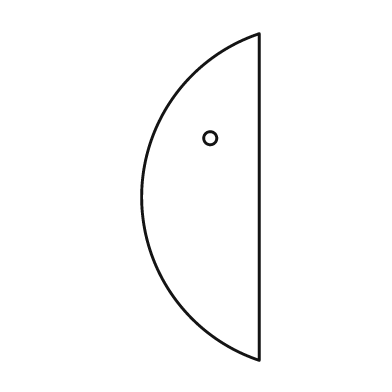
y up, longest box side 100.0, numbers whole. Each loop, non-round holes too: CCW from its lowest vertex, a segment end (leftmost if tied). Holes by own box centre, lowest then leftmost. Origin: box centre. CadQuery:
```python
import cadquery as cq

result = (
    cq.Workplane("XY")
    .moveTo(18.0, -50.0)
    .lineTo(18.0, 50.0)
    .threePointArc((-18.0, 0.0), (18.0, -50.0))
    .close()
    .moveTo(3.0, 18.0)
    .circle(2.0)
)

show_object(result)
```